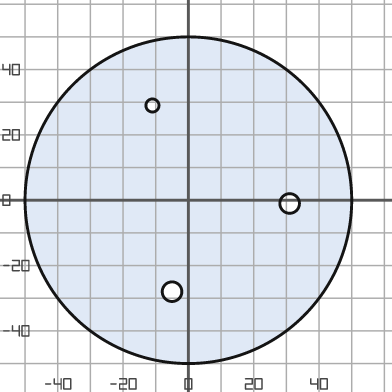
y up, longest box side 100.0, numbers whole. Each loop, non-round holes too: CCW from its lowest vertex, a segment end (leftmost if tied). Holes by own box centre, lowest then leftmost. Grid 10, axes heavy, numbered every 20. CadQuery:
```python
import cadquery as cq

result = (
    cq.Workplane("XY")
    .moveTo(0.0, 0.0)
    .circle(50.0)
    .moveTo(-5.0, -28.0)
    .circle(3.0)
    .moveTo(31.0, -1.0)
    .circle(3.0)
    .moveTo(-11.0, 29.0)
    .circle(2.0)
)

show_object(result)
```